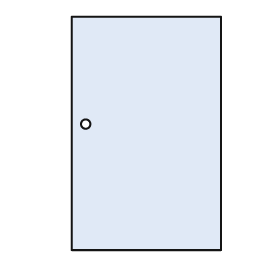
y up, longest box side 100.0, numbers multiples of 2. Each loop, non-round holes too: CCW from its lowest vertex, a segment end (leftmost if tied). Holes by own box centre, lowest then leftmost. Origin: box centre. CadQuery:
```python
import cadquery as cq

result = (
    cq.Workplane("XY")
    .moveTo(-32.0, -50.0)
    .lineTo(32.0, -50.0)
    .lineTo(32.0, 50.0)
    .lineTo(-32.0, 50.0)
    .close()
    .moveTo(-26.0, 4.0)
    .circle(2.0)
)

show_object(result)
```